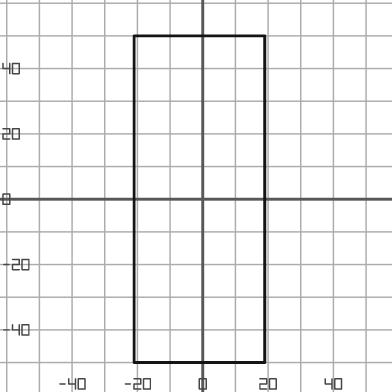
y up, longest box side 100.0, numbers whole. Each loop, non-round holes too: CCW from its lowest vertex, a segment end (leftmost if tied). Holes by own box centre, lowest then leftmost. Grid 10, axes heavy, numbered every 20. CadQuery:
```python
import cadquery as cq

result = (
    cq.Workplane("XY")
    .moveTo(-21.0, -50.0)
    .lineTo(19.0, -50.0)
    .lineTo(19.0, 50.0)
    .lineTo(-21.0, 50.0)
    .close()
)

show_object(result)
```